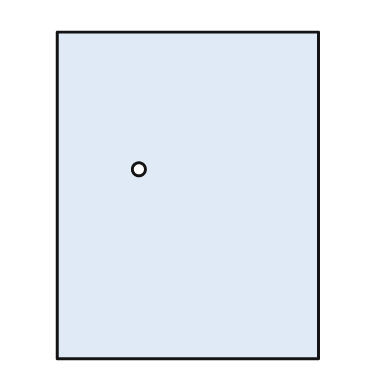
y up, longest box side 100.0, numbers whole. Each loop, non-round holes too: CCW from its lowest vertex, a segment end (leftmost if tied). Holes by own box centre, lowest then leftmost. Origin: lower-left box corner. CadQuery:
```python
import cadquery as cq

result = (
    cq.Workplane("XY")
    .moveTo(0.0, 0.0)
    .lineTo(80.0, 0.0)
    .lineTo(80.0, 100.0)
    .lineTo(0.0, 100.0)
    .close()
    .moveTo(25.0, 58.0)
    .circle(2.0)
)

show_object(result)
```